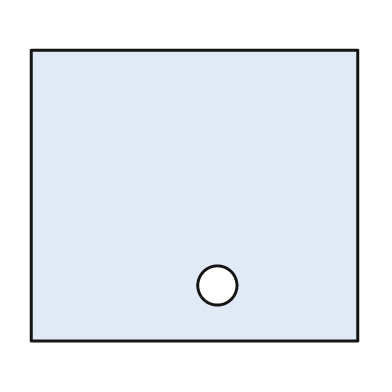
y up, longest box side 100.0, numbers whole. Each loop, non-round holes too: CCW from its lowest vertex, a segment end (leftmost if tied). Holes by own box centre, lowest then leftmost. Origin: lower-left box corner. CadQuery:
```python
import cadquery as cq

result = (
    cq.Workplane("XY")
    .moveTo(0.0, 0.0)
    .lineTo(100.0, 0.0)
    .lineTo(100.0, 89.0)
    .lineTo(0.0, 89.0)
    .close()
    .moveTo(57.0, 17.0)
    .circle(6.0)
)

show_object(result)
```